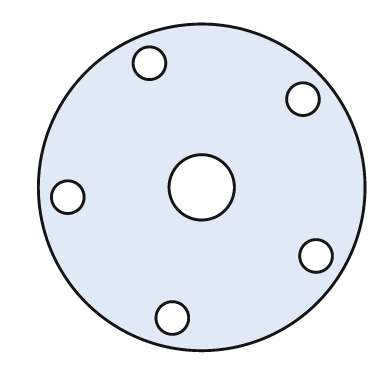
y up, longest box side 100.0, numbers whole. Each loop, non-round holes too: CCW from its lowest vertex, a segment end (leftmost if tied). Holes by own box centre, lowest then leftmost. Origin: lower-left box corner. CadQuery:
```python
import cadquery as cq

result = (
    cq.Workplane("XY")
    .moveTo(50.0, 50.0)
    .circle(50.0)
    .moveTo(41.0, 10.0)
    .circle(5.0)
    .moveTo(85.0, 29.0)
    .circle(5.0)
    .moveTo(9.0, 47.0)
    .circle(5.0)
    .moveTo(50.0, 50.0)
    .circle(10.0)
    .moveTo(81.0, 77.0)
    .circle(5.0)
    .moveTo(34.0, 88.0)
    .circle(5.0)
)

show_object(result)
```